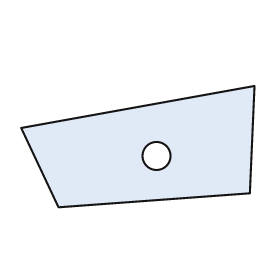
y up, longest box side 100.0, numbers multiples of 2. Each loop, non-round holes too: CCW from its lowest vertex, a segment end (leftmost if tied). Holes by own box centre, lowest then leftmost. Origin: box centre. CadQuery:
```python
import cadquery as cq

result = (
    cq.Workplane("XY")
    .moveTo(-34.0, -26.0)
    .lineTo(48.0, -20.0)
    .lineTo(50.0, 26.0)
    .lineTo(-50.0, 8.0)
    .close()
    .moveTo(8.0, -4.0)
    .circle(6.0)
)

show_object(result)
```